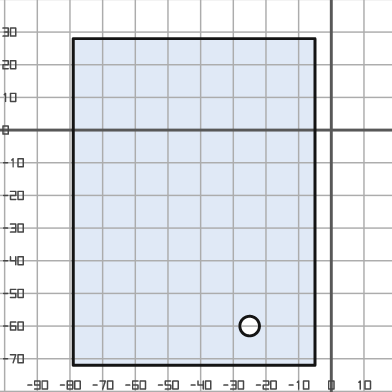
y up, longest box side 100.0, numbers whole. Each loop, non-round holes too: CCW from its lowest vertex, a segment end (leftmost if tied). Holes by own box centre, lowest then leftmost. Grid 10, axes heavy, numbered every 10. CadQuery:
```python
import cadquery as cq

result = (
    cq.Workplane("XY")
    .moveTo(-79.0, -72.0)
    .lineTo(-5.0, -72.0)
    .lineTo(-5.0, 28.0)
    .lineTo(-79.0, 28.0)
    .close()
    .moveTo(-25.0, -60.0)
    .circle(3.0)
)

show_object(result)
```